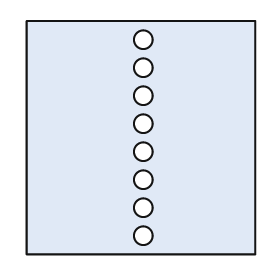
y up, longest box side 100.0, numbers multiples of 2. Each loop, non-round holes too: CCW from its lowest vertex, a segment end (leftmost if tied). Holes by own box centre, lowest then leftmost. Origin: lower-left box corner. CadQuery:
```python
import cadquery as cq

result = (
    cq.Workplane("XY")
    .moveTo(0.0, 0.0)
    .lineTo(98.0, 0.0)
    .lineTo(98.0, 100.0)
    .lineTo(0.0, 100.0)
    .close()
    .moveTo(50.0, 8.0)
    .circle(4.0)
    .moveTo(50.0, 20.0)
    .circle(4.0)
    .moveTo(50.0, 32.0)
    .circle(4.0)
    .moveTo(50.0, 44.0)
    .circle(4.0)
    .moveTo(50.0, 56.0)
    .circle(4.0)
    .moveTo(50.0, 68.0)
    .circle(4.0)
    .moveTo(50.0, 80.0)
    .circle(4.0)
    .moveTo(50.0, 92.0)
    .circle(4.0)
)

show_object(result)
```